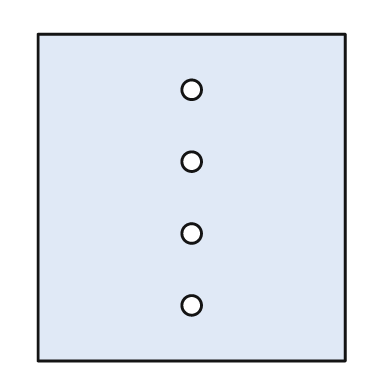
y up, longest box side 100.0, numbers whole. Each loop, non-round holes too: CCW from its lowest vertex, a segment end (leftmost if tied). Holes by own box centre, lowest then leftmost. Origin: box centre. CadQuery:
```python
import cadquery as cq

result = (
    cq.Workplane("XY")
    .moveTo(-47.0, -50.0)
    .lineTo(47.0, -50.0)
    .lineTo(47.0, 50.0)
    .lineTo(-47.0, 50.0)
    .close()
    .moveTo(0.0, -33.0)
    .circle(3.0)
    .moveTo(0.0, -11.0)
    .circle(3.0)
    .moveTo(0.0, 11.0)
    .circle(3.0)
    .moveTo(0.0, 33.0)
    .circle(3.0)
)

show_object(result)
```